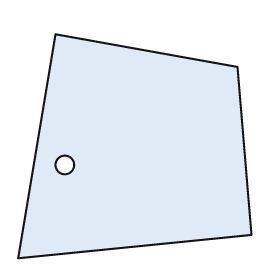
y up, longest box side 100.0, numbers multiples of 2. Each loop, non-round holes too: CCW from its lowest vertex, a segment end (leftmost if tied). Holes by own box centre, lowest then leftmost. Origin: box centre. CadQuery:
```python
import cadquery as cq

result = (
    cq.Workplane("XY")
    .moveTo(-50.0, -48.0)
    .lineTo(50.0, -38.0)
    .lineTo(44.0, 34.0)
    .lineTo(-34.0, 48.0)
    .close()
    .moveTo(-30.0, -8.0)
    .circle(4.0)
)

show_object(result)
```